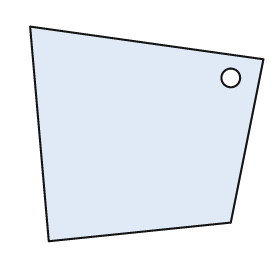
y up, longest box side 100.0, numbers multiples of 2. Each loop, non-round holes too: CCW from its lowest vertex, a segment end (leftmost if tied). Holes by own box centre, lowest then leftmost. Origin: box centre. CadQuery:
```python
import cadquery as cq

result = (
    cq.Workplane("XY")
    .moveTo(-42.0, -46.0)
    .lineTo(36.0, -38.0)
    .lineTo(50.0, 32.0)
    .lineTo(-50.0, 46.0)
    .close()
    .moveTo(36.0, 24.0)
    .circle(4.0)
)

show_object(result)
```